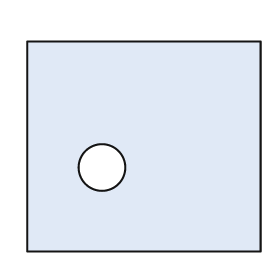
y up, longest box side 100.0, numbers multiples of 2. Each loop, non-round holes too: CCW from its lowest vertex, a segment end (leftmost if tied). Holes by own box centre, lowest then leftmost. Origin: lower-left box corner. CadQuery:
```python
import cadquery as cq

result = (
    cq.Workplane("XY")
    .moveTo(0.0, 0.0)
    .lineTo(100.0, 0.0)
    .lineTo(100.0, 90.0)
    .lineTo(0.0, 90.0)
    .close()
    .moveTo(32.0, 36.0)
    .circle(10.0)
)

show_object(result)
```